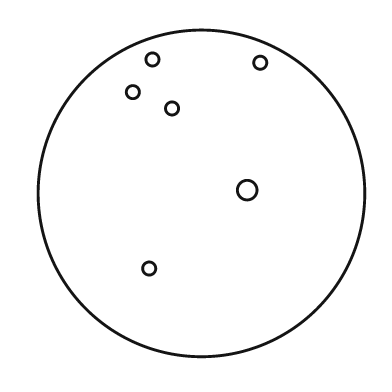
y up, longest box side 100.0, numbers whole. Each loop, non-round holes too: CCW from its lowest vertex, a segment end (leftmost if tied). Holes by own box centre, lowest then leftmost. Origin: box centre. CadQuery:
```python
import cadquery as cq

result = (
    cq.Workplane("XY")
    .moveTo(0.0, 0.0)
    .circle(50.0)
    .moveTo(-16.0, -23.0)
    .circle(2.0)
    .moveTo(14.0, 1.0)
    .circle(3.0)
    .moveTo(-9.0, 26.0)
    .circle(2.0)
    .moveTo(-21.0, 31.0)
    .circle(2.0)
    .moveTo(18.0, 40.0)
    .circle(2.0)
    .moveTo(-15.0, 41.0)
    .circle(2.0)
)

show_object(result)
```